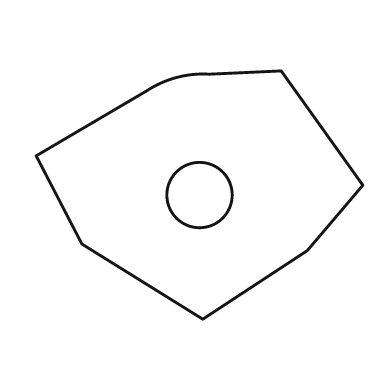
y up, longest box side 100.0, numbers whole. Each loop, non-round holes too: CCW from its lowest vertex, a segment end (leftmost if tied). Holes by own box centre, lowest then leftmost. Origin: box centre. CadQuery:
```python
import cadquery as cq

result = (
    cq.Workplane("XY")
    .moveTo(1.0, -38.0)
    .lineTo(33.0, -17.0)
    .lineTo(50.0, 3.0)
    .lineTo(25.0, 38.0)
    .lineTo(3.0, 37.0)
    .threePointArc((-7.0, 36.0), (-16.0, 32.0))
    .lineTo(-50.0, 12.0)
    .lineTo(-36.0, -15.0)
    .close()
    .moveTo(0.0, 0.0)
    .circle(10.0)
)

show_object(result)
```